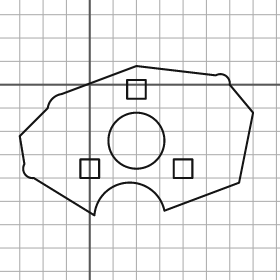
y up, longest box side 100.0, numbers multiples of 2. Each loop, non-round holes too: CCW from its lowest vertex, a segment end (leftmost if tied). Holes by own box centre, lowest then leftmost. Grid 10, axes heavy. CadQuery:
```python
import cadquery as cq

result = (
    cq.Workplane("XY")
    .moveTo(2.0, -56.0)
    .threePointArc((16.0, -42.0), (32.0, -54.0))
    .lineTo(64.0, -42.0)
    .lineTo(70.0, -12.0)
    .lineTo(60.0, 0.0)
    .threePointArc((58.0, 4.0), (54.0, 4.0))
    .lineTo(20.0, 8.0)
    .lineTo(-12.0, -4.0)
    .threePointArc((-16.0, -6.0), (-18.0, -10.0))
    .lineTo(-30.0, -22.0)
    .lineTo(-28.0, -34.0)
    .threePointArc((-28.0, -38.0), (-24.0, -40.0))
    .close()
    .moveTo(-4.0, -40.0)
    .lineTo(4.0, -40.0)
    .lineTo(4.0, -32.0)
    .lineTo(-4.0, -32.0)
    .close()
    .moveTo(36.0, -40.0)
    .lineTo(44.0, -40.0)
    .lineTo(44.0, -32.0)
    .lineTo(36.0, -32.0)
    .close()
    .moveTo(20.0, -24.0)
    .circle(12.0)
    .moveTo(16.0, -6.0)
    .lineTo(24.0, -6.0)
    .lineTo(24.0, 2.0)
    .lineTo(16.0, 2.0)
    .close()
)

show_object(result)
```